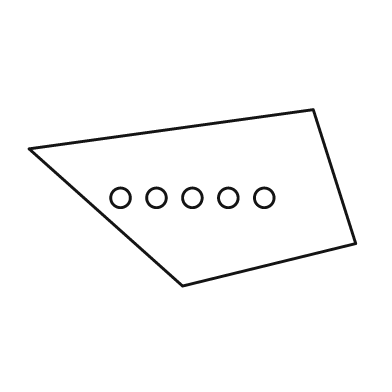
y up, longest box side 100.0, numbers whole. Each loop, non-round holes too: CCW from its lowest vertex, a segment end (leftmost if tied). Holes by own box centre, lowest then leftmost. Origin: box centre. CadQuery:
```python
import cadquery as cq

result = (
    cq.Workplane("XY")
    .moveTo(-3.0, -27.0)
    .lineTo(50.0, -14.0)
    .lineTo(37.0, 27.0)
    .lineTo(-50.0, 15.0)
    .close()
    .moveTo(-22.0, 0.0)
    .circle(3.0)
    .moveTo(-11.0, 0.0)
    .circle(3.0)
    .moveTo(0.0, 0.0)
    .circle(3.0)
    .moveTo(11.0, 0.0)
    .circle(3.0)
    .moveTo(22.0, 0.0)
    .circle(3.0)
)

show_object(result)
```